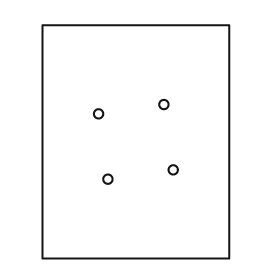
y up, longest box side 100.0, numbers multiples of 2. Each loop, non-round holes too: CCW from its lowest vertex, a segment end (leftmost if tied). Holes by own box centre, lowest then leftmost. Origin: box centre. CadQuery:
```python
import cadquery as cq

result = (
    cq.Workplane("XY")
    .moveTo(-40.0, -50.0)
    .lineTo(40.0, -50.0)
    .lineTo(40.0, 50.0)
    .lineTo(-40.0, 50.0)
    .close()
    .moveTo(-12.0, -16.0)
    .circle(2.0)
    .moveTo(16.0, -12.0)
    .circle(2.0)
    .moveTo(-16.0, 12.0)
    .circle(2.0)
    .moveTo(12.0, 16.0)
    .circle(2.0)
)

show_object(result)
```